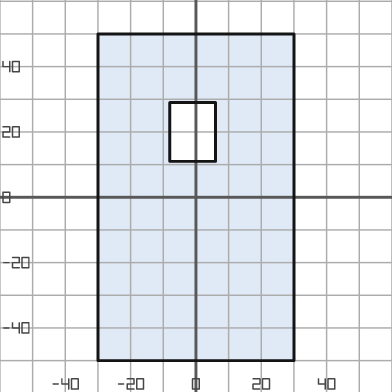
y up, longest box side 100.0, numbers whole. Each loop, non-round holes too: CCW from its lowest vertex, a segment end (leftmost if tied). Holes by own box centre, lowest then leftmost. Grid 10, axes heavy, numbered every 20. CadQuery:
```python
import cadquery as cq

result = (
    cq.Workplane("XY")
    .moveTo(-30.0, -50.0)
    .lineTo(30.0, -50.0)
    .lineTo(30.0, 50.0)
    .lineTo(-30.0, 50.0)
    .close()
    .moveTo(-8.0, 11.0)
    .lineTo(6.0, 11.0)
    .lineTo(6.0, 29.0)
    .lineTo(-8.0, 29.0)
    .close()
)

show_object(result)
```